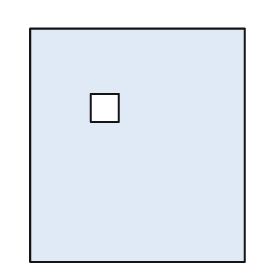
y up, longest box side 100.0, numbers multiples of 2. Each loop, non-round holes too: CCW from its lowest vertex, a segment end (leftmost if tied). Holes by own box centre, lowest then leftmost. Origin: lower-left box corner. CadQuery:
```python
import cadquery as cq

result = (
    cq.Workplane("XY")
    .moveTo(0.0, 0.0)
    .lineTo(92.0, 0.0)
    .lineTo(92.0, 100.0)
    .lineTo(0.0, 100.0)
    .close()
    .moveTo(26.0, 60.0)
    .lineTo(38.0, 60.0)
    .lineTo(38.0, 72.0)
    .lineTo(26.0, 72.0)
    .close()
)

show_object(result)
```